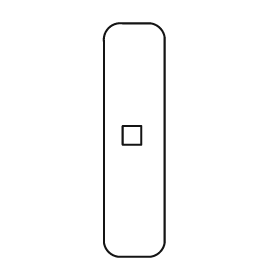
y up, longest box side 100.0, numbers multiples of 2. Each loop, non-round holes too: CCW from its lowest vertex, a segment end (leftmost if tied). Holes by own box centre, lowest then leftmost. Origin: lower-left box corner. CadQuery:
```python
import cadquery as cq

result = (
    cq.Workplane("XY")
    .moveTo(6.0, 0.0)
    .lineTo(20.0, 0.0)
    .threePointArc((24.0, 2.0), (26.0, 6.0))
    .lineTo(26.0, 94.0)
    .threePointArc((24.0, 98.0), (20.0, 100.0))
    .lineTo(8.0, 100.0)
    .threePointArc((2.0, 98.0), (0.0, 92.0))
    .lineTo(0.0, 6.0)
    .threePointArc((2.0, 2.0), (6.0, 0.0))
    .close()
    .moveTo(8.0, 48.0)
    .lineTo(16.0, 48.0)
    .lineTo(16.0, 56.0)
    .lineTo(8.0, 56.0)
    .close()
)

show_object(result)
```